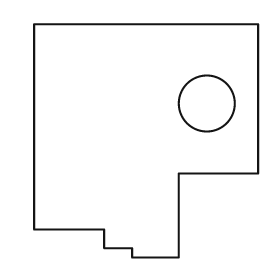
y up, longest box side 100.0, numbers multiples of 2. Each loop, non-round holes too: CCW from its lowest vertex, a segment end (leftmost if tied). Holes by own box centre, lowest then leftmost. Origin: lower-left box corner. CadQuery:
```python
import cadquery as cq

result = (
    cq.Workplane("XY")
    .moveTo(42.0, 0.0)
    .lineTo(62.0, 0.0)
    .lineTo(62.0, 36.0)
    .lineTo(96.0, 36.0)
    .lineTo(96.0, 100.0)
    .lineTo(0.0, 100.0)
    .lineTo(0.0, 12.0)
    .lineTo(30.0, 12.0)
    .lineTo(30.0, 4.0)
    .lineTo(42.0, 4.0)
    .close()
    .moveTo(74.0, 66.0)
    .circle(12.0)
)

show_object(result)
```